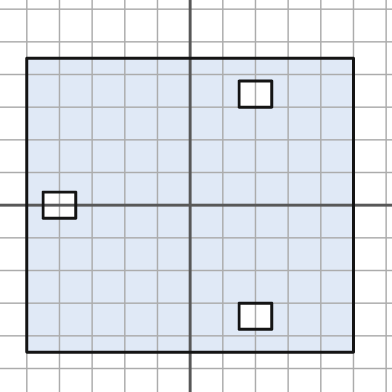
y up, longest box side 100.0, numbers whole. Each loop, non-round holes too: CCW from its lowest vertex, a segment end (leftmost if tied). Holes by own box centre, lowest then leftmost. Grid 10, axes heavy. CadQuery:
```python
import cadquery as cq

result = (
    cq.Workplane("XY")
    .moveTo(-50.0, -45.0)
    .lineTo(50.0, -45.0)
    .lineTo(50.0, 45.0)
    .lineTo(-50.0, 45.0)
    .close()
    .moveTo(15.0, -38.0)
    .lineTo(25.0, -38.0)
    .lineTo(25.0, -30.0)
    .lineTo(15.0, -30.0)
    .close()
    .moveTo(-45.0, -4.0)
    .lineTo(-35.0, -4.0)
    .lineTo(-35.0, 4.0)
    .lineTo(-45.0, 4.0)
    .close()
    .moveTo(15.0, 30.0)
    .lineTo(25.0, 30.0)
    .lineTo(25.0, 38.0)
    .lineTo(15.0, 38.0)
    .close()
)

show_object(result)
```